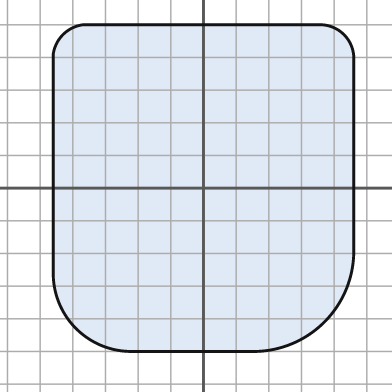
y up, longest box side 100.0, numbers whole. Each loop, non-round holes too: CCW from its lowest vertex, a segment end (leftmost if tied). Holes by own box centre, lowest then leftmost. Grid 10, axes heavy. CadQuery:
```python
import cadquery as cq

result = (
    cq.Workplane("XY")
    .moveTo(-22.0, -50.0)
    .lineTo(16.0, -50.0)
    .threePointArc((37.0, -41.0), (46.0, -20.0))
    .lineTo(46.0, 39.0)
    .threePointArc((43.0, 47.0), (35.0, 50.0))
    .lineTo(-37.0, 50.0)
    .threePointArc((-43.0, 47.0), (-46.0, 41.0))
    .lineTo(-46.0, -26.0)
    .threePointArc((-39.0, -43.0), (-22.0, -50.0))
    .close()
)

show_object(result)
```